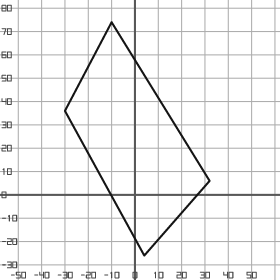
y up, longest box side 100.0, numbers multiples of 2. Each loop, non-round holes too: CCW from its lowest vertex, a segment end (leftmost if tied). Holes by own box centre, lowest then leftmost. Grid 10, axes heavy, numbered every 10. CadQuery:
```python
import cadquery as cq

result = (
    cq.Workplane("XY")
    .moveTo(4.0, -26.0)
    .lineTo(32.0, 6.0)
    .lineTo(-10.0, 74.0)
    .lineTo(-30.0, 36.0)
    .close()
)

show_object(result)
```